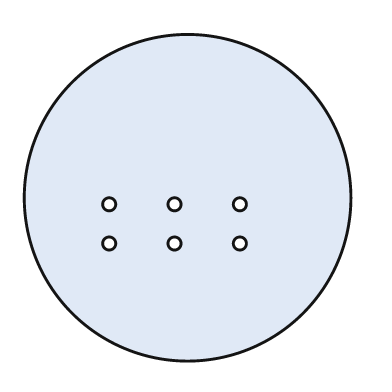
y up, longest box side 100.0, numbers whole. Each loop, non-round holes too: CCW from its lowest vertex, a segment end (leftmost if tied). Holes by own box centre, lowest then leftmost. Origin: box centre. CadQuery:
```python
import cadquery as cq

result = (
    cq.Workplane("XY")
    .moveTo(0.0, 0.0)
    .circle(50.0)
    .moveTo(-24.0, -14.0)
    .circle(2.0)
    .moveTo(-4.0, -14.0)
    .circle(2.0)
    .moveTo(16.0, -14.0)
    .circle(2.0)
    .moveTo(-24.0, -2.0)
    .circle(2.0)
    .moveTo(-4.0, -2.0)
    .circle(2.0)
    .moveTo(16.0, -2.0)
    .circle(2.0)
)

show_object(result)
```